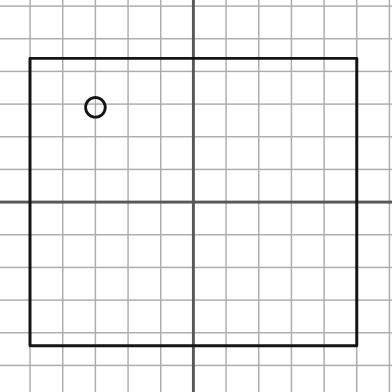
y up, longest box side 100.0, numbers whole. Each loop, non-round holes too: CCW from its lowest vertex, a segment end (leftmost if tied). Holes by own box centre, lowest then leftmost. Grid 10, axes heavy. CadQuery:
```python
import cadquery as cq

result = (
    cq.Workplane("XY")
    .moveTo(-50.0, -44.0)
    .lineTo(50.0, -44.0)
    .lineTo(50.0, 44.0)
    .lineTo(-50.0, 44.0)
    .close()
    .moveTo(-30.0, 29.0)
    .circle(3.0)
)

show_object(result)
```